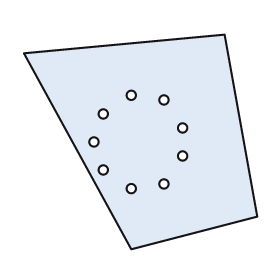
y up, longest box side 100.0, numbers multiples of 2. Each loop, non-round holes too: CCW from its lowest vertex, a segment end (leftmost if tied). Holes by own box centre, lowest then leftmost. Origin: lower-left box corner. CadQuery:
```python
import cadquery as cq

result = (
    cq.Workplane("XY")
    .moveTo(46.0, 0.0)
    .lineTo(100.0, 14.0)
    .lineTo(86.0, 92.0)
    .lineTo(0.0, 84.0)
    .close()
    .moveTo(46.0, 26.0)
    .circle(2.0)
    .moveTo(60.0, 28.0)
    .circle(2.0)
    .moveTo(34.0, 34.0)
    .circle(2.0)
    .moveTo(68.0, 40.0)
    .circle(2.0)
    .moveTo(30.0, 46.0)
    .circle(2.0)
    .moveTo(68.0, 52.0)
    .circle(2.0)
    .moveTo(34.0, 58.0)
    .circle(2.0)
    .moveTo(60.0, 64.0)
    .circle(2.0)
    .moveTo(46.0, 66.0)
    .circle(2.0)
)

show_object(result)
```